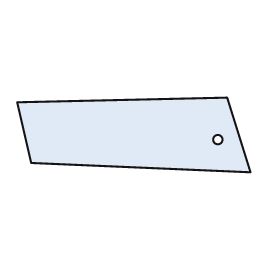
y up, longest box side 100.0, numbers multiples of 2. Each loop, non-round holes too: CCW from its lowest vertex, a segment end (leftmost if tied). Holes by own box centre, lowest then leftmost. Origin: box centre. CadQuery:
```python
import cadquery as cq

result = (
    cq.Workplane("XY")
    .moveTo(50.0, -16.0)
    .lineTo(40.0, 16.0)
    .lineTo(-50.0, 14.0)
    .lineTo(-44.0, -12.0)
    .close()
    .moveTo(36.0, -2.0)
    .circle(2.0)
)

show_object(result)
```